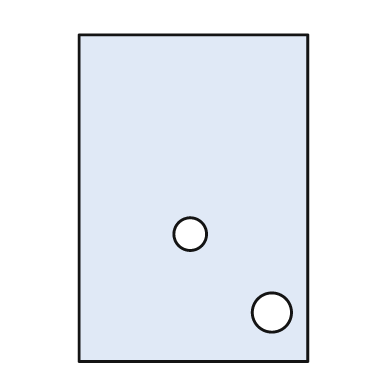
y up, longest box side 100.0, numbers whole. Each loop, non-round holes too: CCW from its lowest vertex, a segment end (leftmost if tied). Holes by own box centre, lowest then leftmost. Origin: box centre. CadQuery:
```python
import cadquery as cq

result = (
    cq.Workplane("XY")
    .moveTo(-35.0, -50.0)
    .lineTo(35.0, -50.0)
    .lineTo(35.0, 50.0)
    .lineTo(-35.0, 50.0)
    .close()
    .moveTo(24.0, -35.0)
    .circle(6.0)
    .moveTo(-1.0, -11.0)
    .circle(5.0)
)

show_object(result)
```